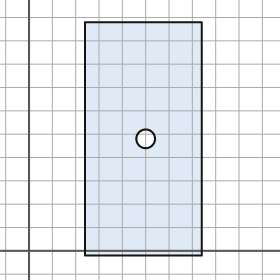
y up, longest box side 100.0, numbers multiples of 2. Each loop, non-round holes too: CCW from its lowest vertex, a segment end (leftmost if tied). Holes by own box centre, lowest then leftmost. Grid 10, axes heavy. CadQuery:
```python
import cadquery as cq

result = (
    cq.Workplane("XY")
    .moveTo(24.0, -2.0)
    .lineTo(74.0, -2.0)
    .lineTo(74.0, 98.0)
    .lineTo(24.0, 98.0)
    .close()
    .moveTo(50.0, 48.0)
    .circle(4.0)
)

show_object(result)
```